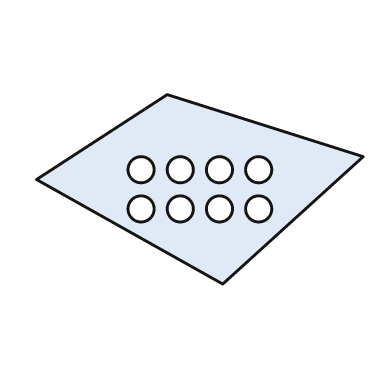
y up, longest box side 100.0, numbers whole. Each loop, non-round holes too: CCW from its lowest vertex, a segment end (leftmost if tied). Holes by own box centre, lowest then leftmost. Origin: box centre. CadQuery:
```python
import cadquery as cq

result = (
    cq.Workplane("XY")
    .moveTo(7.0, -29.0)
    .lineTo(50.0, 10.0)
    .lineTo(-10.0, 29.0)
    .lineTo(-50.0, 3.0)
    .close()
    .moveTo(-18.0, -6.0)
    .circle(4.0)
    .moveTo(-6.0, -6.0)
    .circle(4.0)
    .moveTo(6.0, -6.0)
    .circle(4.0)
    .moveTo(18.0, -6.0)
    .circle(4.0)
    .moveTo(-18.0, 6.0)
    .circle(4.0)
    .moveTo(-6.0, 6.0)
    .circle(4.0)
    .moveTo(6.0, 6.0)
    .circle(4.0)
    .moveTo(18.0, 6.0)
    .circle(4.0)
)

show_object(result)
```